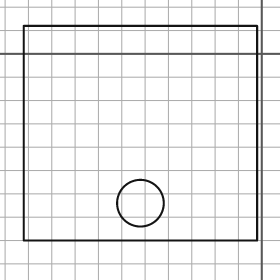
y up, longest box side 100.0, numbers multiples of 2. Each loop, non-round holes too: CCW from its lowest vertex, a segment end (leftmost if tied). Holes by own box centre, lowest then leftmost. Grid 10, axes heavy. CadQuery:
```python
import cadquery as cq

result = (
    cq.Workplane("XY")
    .moveTo(-102.0, -80.0)
    .lineTo(-2.0, -80.0)
    .lineTo(-2.0, 12.0)
    .lineTo(-102.0, 12.0)
    .close()
    .moveTo(-52.0, -64.0)
    .circle(10.0)
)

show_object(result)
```